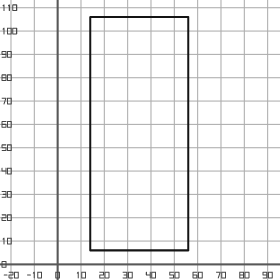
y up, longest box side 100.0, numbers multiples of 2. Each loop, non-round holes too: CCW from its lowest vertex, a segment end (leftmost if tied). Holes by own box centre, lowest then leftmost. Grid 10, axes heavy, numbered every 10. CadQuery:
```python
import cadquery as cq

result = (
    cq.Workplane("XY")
    .moveTo(14.0, 6.0)
    .lineTo(56.0, 6.0)
    .lineTo(56.0, 106.0)
    .lineTo(14.0, 106.0)
    .close()
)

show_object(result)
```